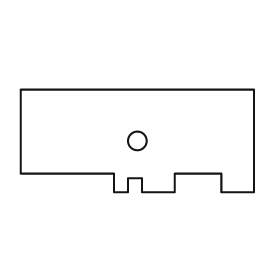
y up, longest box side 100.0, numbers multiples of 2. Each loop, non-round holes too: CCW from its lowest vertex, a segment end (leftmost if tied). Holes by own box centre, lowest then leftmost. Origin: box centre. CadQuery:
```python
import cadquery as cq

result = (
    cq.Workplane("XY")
    .moveTo(-10.0, -22.0)
    .lineTo(-4.0, -22.0)
    .lineTo(-4.0, -16.0)
    .lineTo(2.0, -16.0)
    .lineTo(2.0, -22.0)
    .lineTo(16.0, -22.0)
    .lineTo(16.0, -14.0)
    .lineTo(36.0, -14.0)
    .lineTo(36.0, -22.0)
    .lineTo(50.0, -22.0)
    .lineTo(50.0, 22.0)
    .lineTo(-50.0, 22.0)
    .lineTo(-50.0, -14.0)
    .lineTo(-10.0, -14.0)
    .close()
    .moveTo(0.0, 0.0)
    .circle(4.0)
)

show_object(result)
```